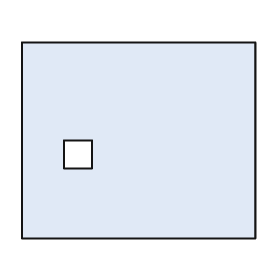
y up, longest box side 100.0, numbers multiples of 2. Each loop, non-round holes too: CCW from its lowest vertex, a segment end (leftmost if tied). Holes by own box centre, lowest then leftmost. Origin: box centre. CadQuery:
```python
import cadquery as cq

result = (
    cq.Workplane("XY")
    .moveTo(-50.0, -42.0)
    .lineTo(50.0, -42.0)
    .lineTo(50.0, 42.0)
    .lineTo(-50.0, 42.0)
    .close()
    .moveTo(-32.0, -12.0)
    .lineTo(-20.0, -12.0)
    .lineTo(-20.0, 0.0)
    .lineTo(-32.0, 0.0)
    .close()
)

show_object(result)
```